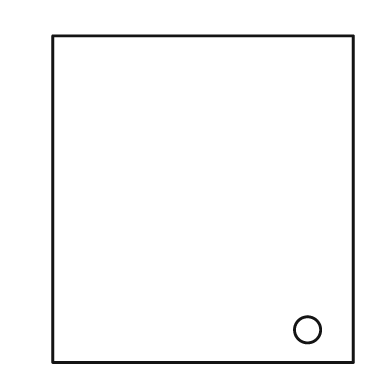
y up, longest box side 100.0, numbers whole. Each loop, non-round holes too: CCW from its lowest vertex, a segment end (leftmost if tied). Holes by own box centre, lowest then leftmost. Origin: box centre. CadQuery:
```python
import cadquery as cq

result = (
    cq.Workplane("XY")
    .moveTo(-46.0, -50.0)
    .lineTo(46.0, -50.0)
    .lineTo(46.0, 50.0)
    .lineTo(-46.0, 50.0)
    .close()
    .moveTo(32.0, -40.0)
    .circle(4.0)
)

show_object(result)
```